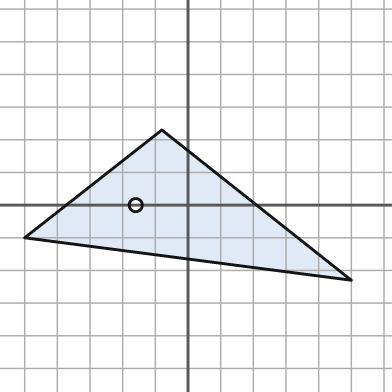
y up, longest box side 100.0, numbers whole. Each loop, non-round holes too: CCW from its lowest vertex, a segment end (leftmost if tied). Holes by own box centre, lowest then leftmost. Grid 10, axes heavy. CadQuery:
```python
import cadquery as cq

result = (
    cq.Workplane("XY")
    .moveTo(50.0, -23.0)
    .lineTo(-8.0, 23.0)
    .lineTo(-50.0, -10.0)
    .close()
    .moveTo(-16.0, 0.0)
    .circle(2.0)
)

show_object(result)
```